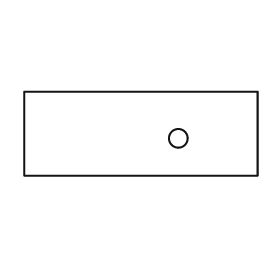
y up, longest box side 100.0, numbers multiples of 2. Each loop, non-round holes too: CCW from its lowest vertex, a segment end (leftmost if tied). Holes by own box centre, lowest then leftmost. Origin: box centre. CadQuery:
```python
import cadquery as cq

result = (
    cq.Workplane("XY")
    .moveTo(-50.0, -18.0)
    .lineTo(50.0, -18.0)
    .lineTo(50.0, 18.0)
    .lineTo(-50.0, 18.0)
    .close()
    .moveTo(16.0, -2.0)
    .circle(4.0)
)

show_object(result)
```